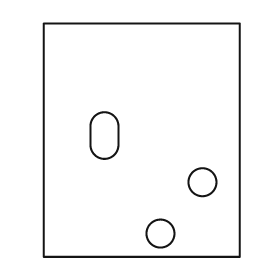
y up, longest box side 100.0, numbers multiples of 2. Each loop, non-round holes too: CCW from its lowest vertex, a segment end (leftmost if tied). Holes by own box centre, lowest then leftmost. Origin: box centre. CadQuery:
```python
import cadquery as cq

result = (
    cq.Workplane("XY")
    .moveTo(-42.0, -50.0)
    .lineTo(42.0, -50.0)
    .lineTo(42.0, 50.0)
    .lineTo(-42.0, 50.0)
    .close()
    .moveTo(8.0, -40.0)
    .circle(6.0)
    .moveTo(26.0, -18.0)
    .circle(6.0)
    .moveTo(-22.0, -2.0)
    .threePointArc((-16.0, -8.0), (-10.0, -2.0))
    .lineTo(-10.0, 6.0)
    .threePointArc((-16.0, 12.0), (-22.0, 6.0))
    .close()
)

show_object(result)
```